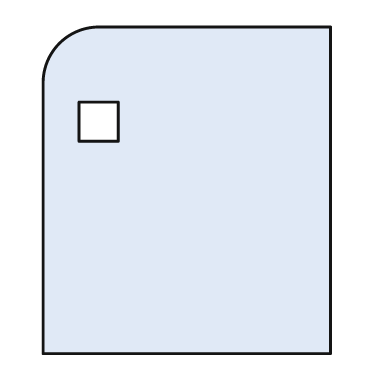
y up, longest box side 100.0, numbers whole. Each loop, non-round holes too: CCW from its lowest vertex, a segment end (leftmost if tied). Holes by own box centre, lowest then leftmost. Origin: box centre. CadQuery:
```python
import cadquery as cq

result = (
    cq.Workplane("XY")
    .moveTo(-44.0, -50.0)
    .lineTo(44.0, -50.0)
    .lineTo(44.0, 50.0)
    .lineTo(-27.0, 50.0)
    .threePointArc((-39.0, 45.0), (-44.0, 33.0))
    .close()
    .moveTo(-33.0, 15.0)
    .lineTo(-21.0, 15.0)
    .lineTo(-21.0, 27.0)
    .lineTo(-33.0, 27.0)
    .close()
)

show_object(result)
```